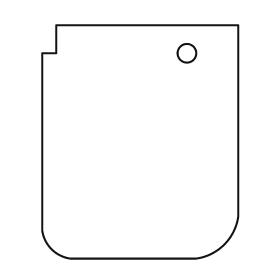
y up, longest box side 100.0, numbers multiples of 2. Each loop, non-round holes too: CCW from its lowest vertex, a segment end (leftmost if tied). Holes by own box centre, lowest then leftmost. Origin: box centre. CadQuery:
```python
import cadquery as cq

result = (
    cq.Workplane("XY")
    .moveTo(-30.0, -50.0)
    .lineTo(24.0, -50.0)
    .threePointArc((36.0, -44.0), (42.0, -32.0))
    .lineTo(42.0, 50.0)
    .lineTo(-36.0, 50.0)
    .lineTo(-36.0, 38.0)
    .lineTo(-42.0, 38.0)
    .lineTo(-42.0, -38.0)
    .threePointArc((-38.0, -46.0), (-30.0, -50.0))
    .close()
    .moveTo(20.0, 38.0)
    .circle(4.0)
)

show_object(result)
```